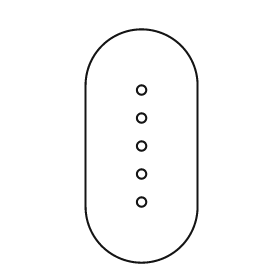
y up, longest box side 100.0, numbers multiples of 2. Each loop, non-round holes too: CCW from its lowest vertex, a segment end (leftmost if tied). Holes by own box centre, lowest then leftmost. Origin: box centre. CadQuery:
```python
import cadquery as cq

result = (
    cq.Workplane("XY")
    .moveTo(-24.0, -26.0)
    .threePointArc((0.0, -50.0), (24.0, -26.0))
    .lineTo(24.0, 26.0)
    .threePointArc((0.0, 50.0), (-24.0, 26.0))
    .close()
    .moveTo(0.0, -24.0)
    .circle(2.0)
    .moveTo(0.0, -12.0)
    .circle(2.0)
    .moveTo(0.0, 0.0)
    .circle(2.0)
    .moveTo(0.0, 12.0)
    .circle(2.0)
    .moveTo(0.0, 24.0)
    .circle(2.0)
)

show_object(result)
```